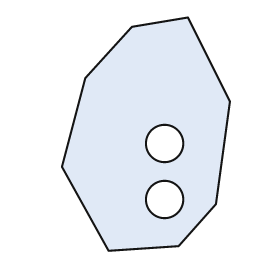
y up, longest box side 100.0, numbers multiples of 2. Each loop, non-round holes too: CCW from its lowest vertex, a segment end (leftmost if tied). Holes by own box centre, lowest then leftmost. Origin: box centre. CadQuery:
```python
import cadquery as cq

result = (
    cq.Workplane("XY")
    .moveTo(-16.0, -50.0)
    .lineTo(14.0, -48.0)
    .lineTo(30.0, -30.0)
    .lineTo(36.0, 14.0)
    .lineTo(18.0, 50.0)
    .lineTo(-6.0, 46.0)
    .lineTo(-26.0, 24.0)
    .lineTo(-36.0, -14.0)
    .close()
    .moveTo(8.0, -28.0)
    .circle(8.0)
    .moveTo(8.0, -4.0)
    .circle(8.0)
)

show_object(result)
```